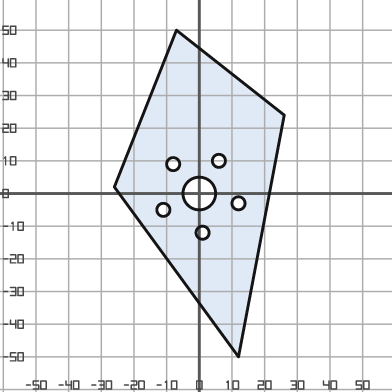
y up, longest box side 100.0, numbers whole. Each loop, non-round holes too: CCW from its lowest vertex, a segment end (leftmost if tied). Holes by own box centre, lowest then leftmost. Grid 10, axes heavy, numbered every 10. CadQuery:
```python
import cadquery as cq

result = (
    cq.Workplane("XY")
    .moveTo(12.0, -50.0)
    .lineTo(26.0, 24.0)
    .lineTo(-7.0, 50.0)
    .lineTo(-26.0, 2.0)
    .close()
    .moveTo(1.0, -12.0)
    .circle(2.0)
    .moveTo(-11.0, -5.0)
    .circle(2.0)
    .moveTo(12.0, -3.0)
    .circle(2.0)
    .moveTo(0.0, 0.0)
    .circle(5.0)
    .moveTo(-8.0, 9.0)
    .circle(2.0)
    .moveTo(6.0, 10.0)
    .circle(2.0)
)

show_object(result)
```